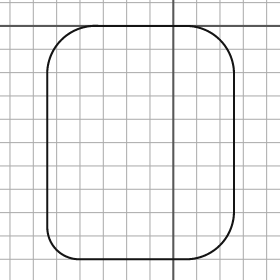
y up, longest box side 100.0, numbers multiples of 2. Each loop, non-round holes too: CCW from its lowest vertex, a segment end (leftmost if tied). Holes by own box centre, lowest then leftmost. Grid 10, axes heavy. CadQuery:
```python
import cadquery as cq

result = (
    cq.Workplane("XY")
    .moveTo(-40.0, -100.0)
    .lineTo(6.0, -100.0)
    .threePointArc((20.0, -94.0), (26.0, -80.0))
    .lineTo(26.0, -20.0)
    .threePointArc((20.0, -6.0), (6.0, 0.0))
    .lineTo(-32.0, 0.0)
    .threePointArc((-48.0, -6.0), (-54.0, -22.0))
    .lineTo(-54.0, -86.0)
    .threePointArc((-50.0, -96.0), (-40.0, -100.0))
    .close()
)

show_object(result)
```